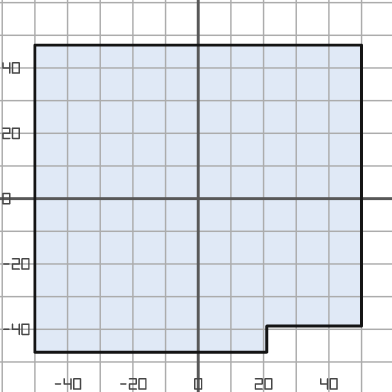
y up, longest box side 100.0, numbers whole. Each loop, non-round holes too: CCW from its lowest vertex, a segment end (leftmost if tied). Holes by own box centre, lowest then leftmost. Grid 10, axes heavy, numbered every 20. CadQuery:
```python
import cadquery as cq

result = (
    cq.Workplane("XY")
    .moveTo(-50.0, -47.0)
    .lineTo(21.0, -47.0)
    .lineTo(21.0, -39.0)
    .lineTo(50.0, -39.0)
    .lineTo(50.0, 47.0)
    .lineTo(-50.0, 47.0)
    .close()
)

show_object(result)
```